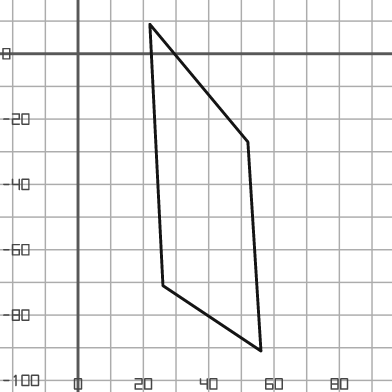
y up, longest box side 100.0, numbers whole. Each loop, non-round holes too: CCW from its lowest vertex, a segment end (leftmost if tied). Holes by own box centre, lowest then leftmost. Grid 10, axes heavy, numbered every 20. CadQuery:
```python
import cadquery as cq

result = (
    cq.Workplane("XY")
    .moveTo(56.0, -91.0)
    .lineTo(52.0, -27.0)
    .lineTo(22.0, 9.0)
    .lineTo(26.0, -71.0)
    .close()
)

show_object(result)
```